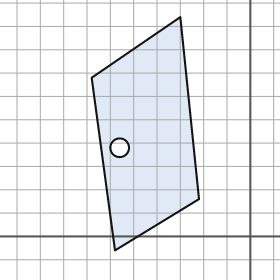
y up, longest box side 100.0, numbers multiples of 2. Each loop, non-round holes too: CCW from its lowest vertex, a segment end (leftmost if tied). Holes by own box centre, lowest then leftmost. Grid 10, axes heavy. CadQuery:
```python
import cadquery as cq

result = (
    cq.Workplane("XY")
    .moveTo(-58.0, -6.0)
    .lineTo(-22.0, 16.0)
    .lineTo(-30.0, 94.0)
    .lineTo(-68.0, 68.0)
    .close()
    .moveTo(-56.0, 38.0)
    .circle(4.0)
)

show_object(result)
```